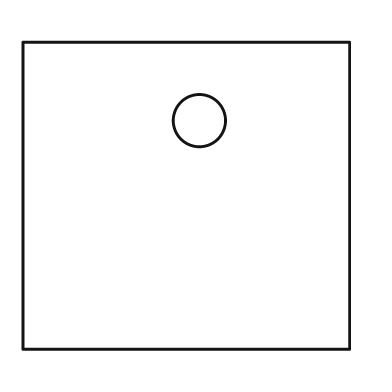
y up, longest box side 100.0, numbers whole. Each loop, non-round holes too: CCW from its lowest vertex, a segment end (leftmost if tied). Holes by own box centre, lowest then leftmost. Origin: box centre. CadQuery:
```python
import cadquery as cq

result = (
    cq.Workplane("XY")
    .moveTo(-50.0, -47.0)
    .lineTo(50.0, -47.0)
    .lineTo(50.0, 47.0)
    .lineTo(-50.0, 47.0)
    .close()
    .moveTo(4.0, 23.0)
    .circle(8.0)
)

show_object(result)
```